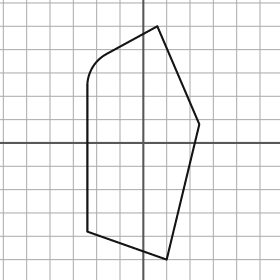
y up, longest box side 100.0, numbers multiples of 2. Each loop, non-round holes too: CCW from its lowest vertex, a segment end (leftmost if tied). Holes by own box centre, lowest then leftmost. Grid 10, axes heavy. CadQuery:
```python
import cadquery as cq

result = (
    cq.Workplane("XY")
    .moveTo(10.0, -50.0)
    .lineTo(24.0, 8.0)
    .lineTo(6.0, 50.0)
    .lineTo(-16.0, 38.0)
    .threePointArc((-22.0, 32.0), (-24.0, 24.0))
    .lineTo(-24.0, -38.0)
    .close()
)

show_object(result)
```